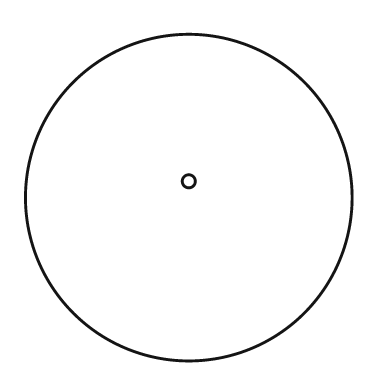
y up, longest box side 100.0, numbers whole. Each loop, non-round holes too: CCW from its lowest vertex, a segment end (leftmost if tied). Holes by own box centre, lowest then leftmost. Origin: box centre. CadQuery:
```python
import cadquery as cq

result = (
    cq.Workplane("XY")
    .moveTo(0.0, 0.0)
    .circle(50.0)
    .moveTo(0.0, 5.0)
    .circle(2.0)
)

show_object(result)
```